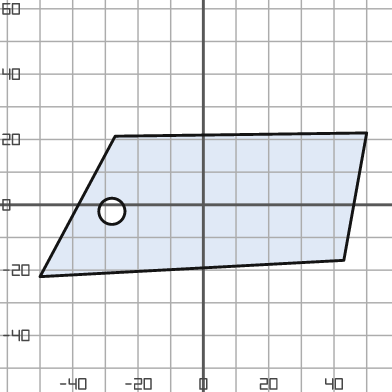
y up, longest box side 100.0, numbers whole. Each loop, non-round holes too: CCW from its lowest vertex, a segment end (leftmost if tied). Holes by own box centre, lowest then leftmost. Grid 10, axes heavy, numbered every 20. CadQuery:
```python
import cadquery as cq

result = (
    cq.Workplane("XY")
    .moveTo(-50.0, -22.0)
    .lineTo(43.0, -17.0)
    .lineTo(50.0, 22.0)
    .lineTo(-27.0, 21.0)
    .close()
    .moveTo(-28.0, -2.0)
    .circle(4.0)
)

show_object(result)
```